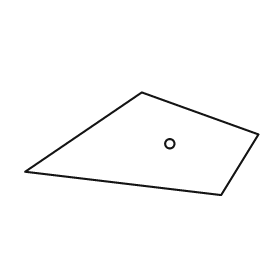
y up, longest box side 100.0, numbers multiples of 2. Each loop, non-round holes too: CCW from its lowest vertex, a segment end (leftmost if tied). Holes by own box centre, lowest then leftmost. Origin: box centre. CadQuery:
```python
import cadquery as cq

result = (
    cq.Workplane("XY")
    .moveTo(34.0, -22.0)
    .lineTo(50.0, 4.0)
    .lineTo(0.0, 22.0)
    .lineTo(-50.0, -12.0)
    .close()
    .moveTo(12.0, 0.0)
    .circle(2.0)
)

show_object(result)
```